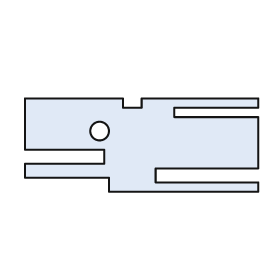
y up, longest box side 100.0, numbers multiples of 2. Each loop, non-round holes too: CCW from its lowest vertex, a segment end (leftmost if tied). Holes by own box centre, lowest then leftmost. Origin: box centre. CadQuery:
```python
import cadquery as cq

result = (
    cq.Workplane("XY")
    .moveTo(-14.0, -20.0)
    .lineTo(50.0, -20.0)
    .lineTo(50.0, -16.0)
    .lineTo(6.0, -16.0)
    .lineTo(6.0, -10.0)
    .lineTo(50.0, -10.0)
    .lineTo(50.0, 12.0)
    .lineTo(14.0, 12.0)
    .lineTo(14.0, 16.0)
    .lineTo(50.0, 16.0)
    .lineTo(50.0, 20.0)
    .lineTo(0.0, 20.0)
    .lineTo(0.0, 16.0)
    .lineTo(-8.0, 16.0)
    .lineTo(-8.0, 20.0)
    .lineTo(-50.0, 20.0)
    .lineTo(-50.0, -2.0)
    .lineTo(-16.0, -2.0)
    .lineTo(-16.0, -8.0)
    .lineTo(-50.0, -8.0)
    .lineTo(-50.0, -14.0)
    .lineTo(-14.0, -14.0)
    .close()
    .moveTo(-18.0, 6.0)
    .circle(4.0)
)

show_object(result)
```